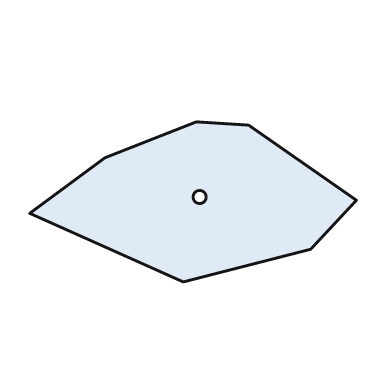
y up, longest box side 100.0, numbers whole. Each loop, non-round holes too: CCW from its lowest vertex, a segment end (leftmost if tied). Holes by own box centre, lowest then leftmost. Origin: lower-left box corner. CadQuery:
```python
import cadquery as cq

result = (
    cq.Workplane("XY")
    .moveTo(47.0, 0.0)
    .lineTo(86.0, 10.0)
    .lineTo(100.0, 25.0)
    .lineTo(67.0, 48.0)
    .lineTo(51.0, 49.0)
    .lineTo(23.0, 38.0)
    .lineTo(0.0, 21.0)
    .close()
    .moveTo(52.0, 26.0)
    .circle(2.0)
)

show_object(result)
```